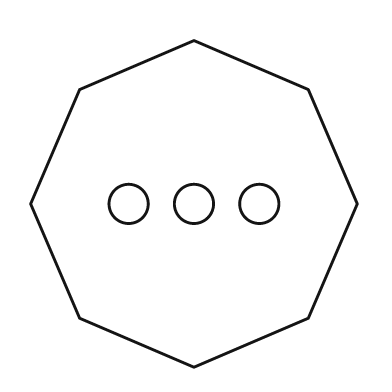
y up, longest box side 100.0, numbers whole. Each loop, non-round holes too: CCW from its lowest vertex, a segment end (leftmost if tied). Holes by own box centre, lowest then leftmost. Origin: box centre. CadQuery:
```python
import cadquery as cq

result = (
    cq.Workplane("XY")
    .moveTo(0.0, -50.0)
    .lineTo(35.0, -35.0)
    .lineTo(50.0, 0.0)
    .lineTo(35.0, 35.0)
    .lineTo(0.0, 50.0)
    .lineTo(-35.0, 35.0)
    .lineTo(-50.0, 0.0)
    .lineTo(-35.0, -35.0)
    .close()
    .moveTo(-20.0, 0.0)
    .circle(6.0)
    .moveTo(0.0, 0.0)
    .circle(6.0)
    .moveTo(20.0, 0.0)
    .circle(6.0)
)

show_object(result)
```